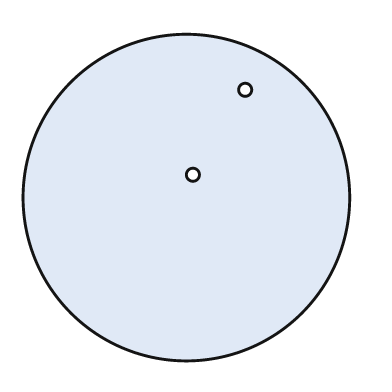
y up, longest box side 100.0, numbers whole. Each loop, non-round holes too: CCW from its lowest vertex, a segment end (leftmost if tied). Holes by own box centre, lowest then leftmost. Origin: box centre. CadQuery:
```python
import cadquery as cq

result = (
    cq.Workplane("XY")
    .moveTo(0.0, 0.0)
    .circle(50.0)
    .moveTo(2.0, 7.0)
    .circle(2.0)
    .moveTo(18.0, 33.0)
    .circle(2.0)
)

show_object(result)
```